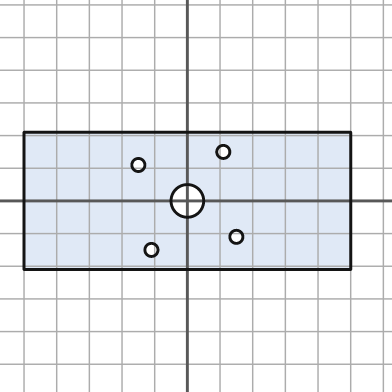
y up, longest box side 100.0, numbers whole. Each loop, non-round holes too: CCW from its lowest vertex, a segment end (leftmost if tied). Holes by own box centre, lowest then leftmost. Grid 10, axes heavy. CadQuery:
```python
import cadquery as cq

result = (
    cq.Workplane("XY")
    .moveTo(-50.0, -21.0)
    .lineTo(50.0, -21.0)
    .lineTo(50.0, 21.0)
    .lineTo(-50.0, 21.0)
    .close()
    .moveTo(-11.0, -15.0)
    .circle(2.0)
    .moveTo(15.0, -11.0)
    .circle(2.0)
    .moveTo(0.0, 0.0)
    .circle(5.0)
    .moveTo(-15.0, 11.0)
    .circle(2.0)
    .moveTo(11.0, 15.0)
    .circle(2.0)
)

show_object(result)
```